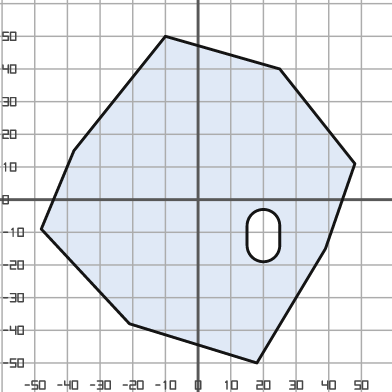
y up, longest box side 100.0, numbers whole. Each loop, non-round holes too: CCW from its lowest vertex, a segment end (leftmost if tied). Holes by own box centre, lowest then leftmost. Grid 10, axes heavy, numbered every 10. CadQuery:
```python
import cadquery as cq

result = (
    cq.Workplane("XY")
    .moveTo(18.0, -50.0)
    .lineTo(39.0, -15.0)
    .lineTo(48.0, 11.0)
    .lineTo(25.0, 40.0)
    .lineTo(-10.0, 50.0)
    .lineTo(-38.0, 15.0)
    .lineTo(-48.0, -9.0)
    .lineTo(-21.0, -38.0)
    .close()
    .moveTo(15.0, -14.0)
    .threePointArc((20.0, -19.0), (25.0, -14.0))
    .lineTo(25.0, -8.0)
    .threePointArc((20.0, -3.0), (15.0, -8.0))
    .close()
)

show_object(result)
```